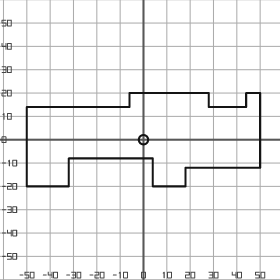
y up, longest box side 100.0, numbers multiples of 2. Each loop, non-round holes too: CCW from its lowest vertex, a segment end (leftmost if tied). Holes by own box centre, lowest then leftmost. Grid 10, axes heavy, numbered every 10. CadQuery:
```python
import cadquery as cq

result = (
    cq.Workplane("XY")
    .moveTo(-50.0, -20.0)
    .lineTo(-32.0, -20.0)
    .lineTo(-32.0, -8.0)
    .lineTo(4.0, -8.0)
    .lineTo(4.0, -20.0)
    .lineTo(18.0, -20.0)
    .lineTo(18.0, -12.0)
    .lineTo(50.0, -12.0)
    .lineTo(50.0, 20.0)
    .lineTo(44.0, 20.0)
    .lineTo(44.0, 14.0)
    .lineTo(28.0, 14.0)
    .lineTo(28.0, 20.0)
    .lineTo(-6.0, 20.0)
    .lineTo(-6.0, 14.0)
    .lineTo(-50.0, 14.0)
    .close()
    .moveTo(0.0, 0.0)
    .circle(2.0)
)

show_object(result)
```